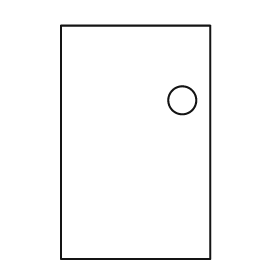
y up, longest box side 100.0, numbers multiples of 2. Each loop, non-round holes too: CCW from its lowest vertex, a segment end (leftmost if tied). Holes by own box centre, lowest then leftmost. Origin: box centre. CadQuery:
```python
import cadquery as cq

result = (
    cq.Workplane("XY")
    .moveTo(-32.0, -50.0)
    .lineTo(32.0, -50.0)
    .lineTo(32.0, 50.0)
    .lineTo(-32.0, 50.0)
    .close()
    .moveTo(20.0, 18.0)
    .circle(6.0)
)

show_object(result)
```